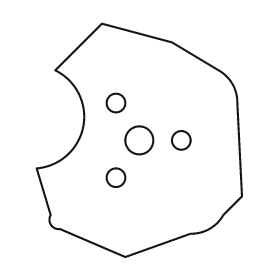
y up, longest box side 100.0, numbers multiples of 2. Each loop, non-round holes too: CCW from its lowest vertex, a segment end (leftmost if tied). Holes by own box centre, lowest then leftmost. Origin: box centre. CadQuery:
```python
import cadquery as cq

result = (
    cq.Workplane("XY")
    .moveTo(-6.0, -50.0)
    .lineTo(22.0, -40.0)
    .threePointArc((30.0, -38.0), (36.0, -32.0))
    .lineTo(44.0, -24.0)
    .lineTo(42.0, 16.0)
    .threePointArc((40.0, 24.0), (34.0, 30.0))
    .lineTo(14.0, 42.0)
    .lineTo(-16.0, 50.0)
    .lineTo(-36.0, 30.0)
    .threePointArc((-24.0, 6.0), (-44.0, -12.0))
    .lineTo(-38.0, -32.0)
    .threePointArc((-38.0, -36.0), (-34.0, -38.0))
    .close()
    .moveTo(-10.0, -16.0)
    .circle(4.0)
    .moveTo(0.0, 0.0)
    .circle(6.0)
    .moveTo(18.0, 0.0)
    .circle(4.0)
    .moveTo(-10.0, 16.0)
    .circle(4.0)
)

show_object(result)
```